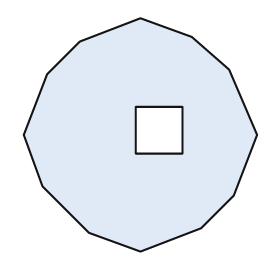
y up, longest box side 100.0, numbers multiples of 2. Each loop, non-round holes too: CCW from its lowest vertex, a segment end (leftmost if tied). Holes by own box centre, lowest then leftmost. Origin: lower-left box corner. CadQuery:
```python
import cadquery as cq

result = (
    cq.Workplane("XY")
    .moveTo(50.0, 0.0)
    .lineTo(76.0, 10.0)
    .lineTo(90.0, 24.0)
    .lineTo(100.0, 50.0)
    .lineTo(88.0, 78.0)
    .lineTo(72.0, 92.0)
    .lineTo(50.0, 100.0)
    .lineTo(24.0, 90.0)
    .lineTo(10.0, 76.0)
    .lineTo(0.0, 50.0)
    .lineTo(8.0, 28.0)
    .lineTo(28.0, 8.0)
    .close()
    .moveTo(48.0, 42.0)
    .lineTo(68.0, 42.0)
    .lineTo(68.0, 62.0)
    .lineTo(48.0, 62.0)
    .close()
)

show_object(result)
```